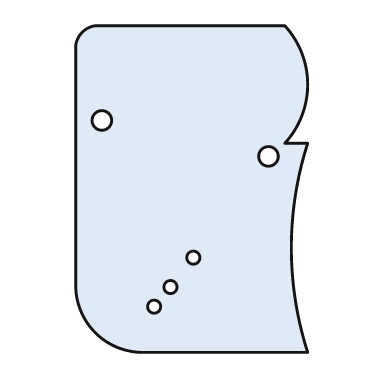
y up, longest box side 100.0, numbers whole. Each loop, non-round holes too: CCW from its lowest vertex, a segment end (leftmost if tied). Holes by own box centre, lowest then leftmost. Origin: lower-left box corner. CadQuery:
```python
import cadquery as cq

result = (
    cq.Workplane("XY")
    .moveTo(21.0, 0.0)
    .lineTo(71.0, 0.0)
    .threePointArc((66.0, 32.0), (71.0, 64.0))
    .lineTo(64.0, 64.0)
    .threePointArc((71.0, 82.0), (64.0, 100.0))
    .lineTo(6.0, 100.0)
    .threePointArc((2.0, 98.0), (0.0, 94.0))
    .lineTo(0.0, 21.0)
    .threePointArc((6.0, 6.0), (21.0, 0.0))
    .close()
    .moveTo(24.0, 14.0)
    .circle(2.0)
    .moveTo(29.0, 20.0)
    .circle(2.0)
    .moveTo(36.0, 29.0)
    .circle(2.0)
    .moveTo(59.0, 60.0)
    .circle(3.0)
    .moveTo(8.0, 71.0)
    .circle(3.0)
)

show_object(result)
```